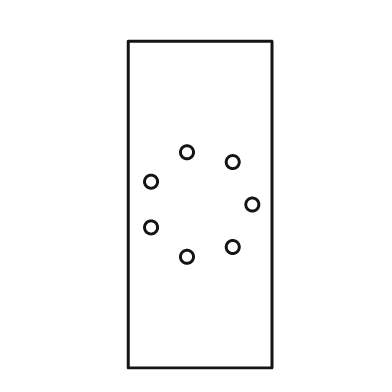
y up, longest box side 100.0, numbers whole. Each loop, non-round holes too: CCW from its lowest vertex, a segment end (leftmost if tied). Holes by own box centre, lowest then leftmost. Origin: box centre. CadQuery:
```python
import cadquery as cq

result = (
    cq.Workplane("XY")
    .moveTo(-22.0, -50.0)
    .lineTo(22.0, -50.0)
    .lineTo(22.0, 50.0)
    .lineTo(-22.0, 50.0)
    .close()
    .moveTo(-4.0, -16.0)
    .circle(2.0)
    .moveTo(10.0, -13.0)
    .circle(2.0)
    .moveTo(-15.0, -7.0)
    .circle(2.0)
    .moveTo(16.0, 0.0)
    .circle(2.0)
    .moveTo(-15.0, 7.0)
    .circle(2.0)
    .moveTo(10.0, 13.0)
    .circle(2.0)
    .moveTo(-4.0, 16.0)
    .circle(2.0)
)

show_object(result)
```